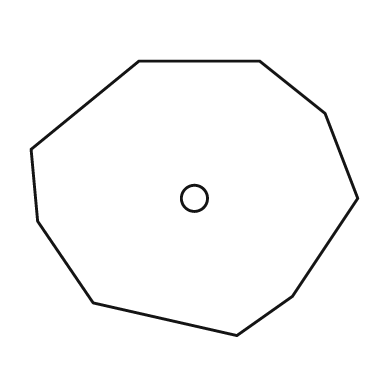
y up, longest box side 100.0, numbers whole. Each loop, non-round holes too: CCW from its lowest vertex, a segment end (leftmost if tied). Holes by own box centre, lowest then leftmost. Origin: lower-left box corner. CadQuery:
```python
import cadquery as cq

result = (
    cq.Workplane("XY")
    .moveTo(63.0, 0.0)
    .lineTo(80.0, 12.0)
    .lineTo(100.0, 42.0)
    .lineTo(90.0, 68.0)
    .lineTo(70.0, 84.0)
    .lineTo(33.0, 84.0)
    .lineTo(0.0, 57.0)
    .lineTo(2.0, 35.0)
    .lineTo(19.0, 10.0)
    .close()
    .moveTo(50.0, 42.0)
    .circle(4.0)
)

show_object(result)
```